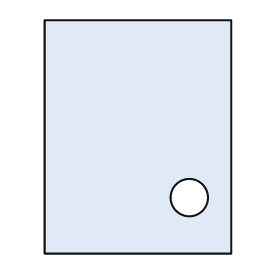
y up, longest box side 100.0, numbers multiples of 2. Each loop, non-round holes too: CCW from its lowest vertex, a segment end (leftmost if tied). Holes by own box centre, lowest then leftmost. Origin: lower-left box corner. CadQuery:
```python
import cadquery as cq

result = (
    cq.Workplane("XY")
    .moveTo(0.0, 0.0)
    .lineTo(80.0, 0.0)
    .lineTo(80.0, 100.0)
    .lineTo(0.0, 100.0)
    .close()
    .moveTo(62.0, 24.0)
    .circle(8.0)
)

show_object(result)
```